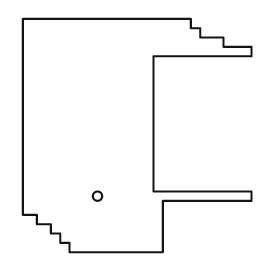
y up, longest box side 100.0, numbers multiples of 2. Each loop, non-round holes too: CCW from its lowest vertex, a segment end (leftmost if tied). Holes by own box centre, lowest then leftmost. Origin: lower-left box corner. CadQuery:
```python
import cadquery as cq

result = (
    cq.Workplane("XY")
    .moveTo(20.0, 0.0)
    .lineTo(60.0, 0.0)
    .lineTo(60.0, 22.0)
    .lineTo(98.0, 22.0)
    .lineTo(98.0, 26.0)
    .lineTo(56.0, 26.0)
    .lineTo(56.0, 84.0)
    .lineTo(98.0, 84.0)
    .lineTo(98.0, 88.0)
    .lineTo(86.0, 88.0)
    .lineTo(86.0, 92.0)
    .lineTo(76.0, 92.0)
    .lineTo(76.0, 96.0)
    .lineTo(72.0, 96.0)
    .lineTo(72.0, 100.0)
    .lineTo(0.0, 100.0)
    .lineTo(0.0, 16.0)
    .lineTo(6.0, 16.0)
    .lineTo(6.0, 12.0)
    .lineTo(12.0, 12.0)
    .lineTo(12.0, 8.0)
    .lineTo(16.0, 8.0)
    .lineTo(16.0, 4.0)
    .lineTo(20.0, 4.0)
    .close()
    .moveTo(32.0, 24.0)
    .circle(2.0)
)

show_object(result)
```